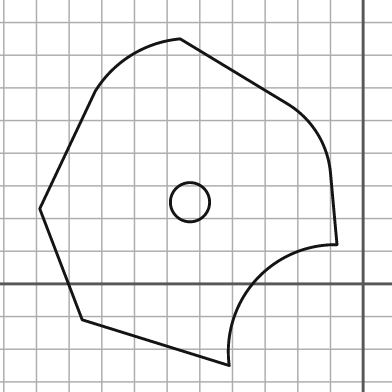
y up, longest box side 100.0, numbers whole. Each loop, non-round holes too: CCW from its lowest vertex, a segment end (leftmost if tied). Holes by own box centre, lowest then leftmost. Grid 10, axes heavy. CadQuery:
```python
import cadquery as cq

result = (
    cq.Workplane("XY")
    .moveTo(-41.0, -25.0)
    .threePointArc((-33.0, 1.0), (-8.0, 12.0))
    .lineTo(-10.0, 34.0)
    .threePointArc((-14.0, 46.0), (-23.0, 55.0))
    .lineTo(-56.0, 75.0)
    .threePointArc((-71.0, 70.0), (-82.0, 59.0))
    .lineTo(-99.0, 23.0)
    .lineTo(-86.0, -11.0)
    .close()
    .moveTo(-53.0, 25.0)
    .circle(6.0)
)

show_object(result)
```